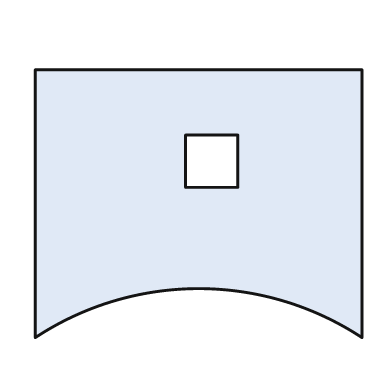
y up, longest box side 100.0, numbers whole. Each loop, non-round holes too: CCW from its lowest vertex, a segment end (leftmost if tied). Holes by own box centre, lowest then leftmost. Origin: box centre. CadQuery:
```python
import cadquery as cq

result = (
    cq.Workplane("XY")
    .moveTo(-50.0, -41.0)
    .threePointArc((0.0, -26.0), (50.0, -41.0))
    .lineTo(50.0, 41.0)
    .lineTo(-50.0, 41.0)
    .close()
    .moveTo(-4.0, 5.0)
    .lineTo(12.0, 5.0)
    .lineTo(12.0, 21.0)
    .lineTo(-4.0, 21.0)
    .close()
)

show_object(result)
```